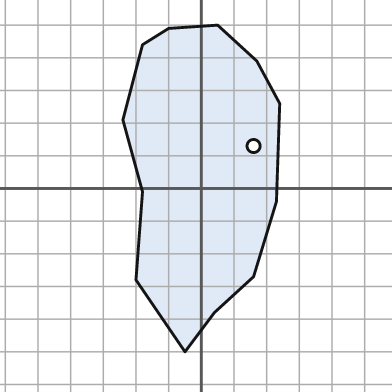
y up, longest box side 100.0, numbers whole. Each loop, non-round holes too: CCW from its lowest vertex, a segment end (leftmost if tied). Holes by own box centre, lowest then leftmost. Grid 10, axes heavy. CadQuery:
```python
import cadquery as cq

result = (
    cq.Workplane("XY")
    .moveTo(-5.0, -50.0)
    .lineTo(4.0, -38.0)
    .lineTo(16.0, -27.0)
    .lineTo(23.0, -4.0)
    .lineTo(24.0, 26.0)
    .lineTo(17.0, 39.0)
    .lineTo(5.0, 50.0)
    .lineTo(-10.0, 49.0)
    .lineTo(-18.0, 44.0)
    .lineTo(-24.0, 21.0)
    .lineTo(-18.0, -1.0)
    .lineTo(-20.0, -28.0)
    .close()
    .moveTo(16.0, 13.0)
    .circle(2.0)
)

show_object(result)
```